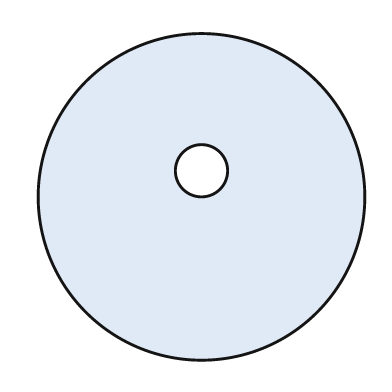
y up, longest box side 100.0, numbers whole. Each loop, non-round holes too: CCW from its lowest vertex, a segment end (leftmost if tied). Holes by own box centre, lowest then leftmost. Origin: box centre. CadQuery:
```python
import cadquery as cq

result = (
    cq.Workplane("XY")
    .moveTo(0.0, 0.0)
    .circle(50.0)
    .moveTo(0.0, 8.0)
    .circle(8.0)
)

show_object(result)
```